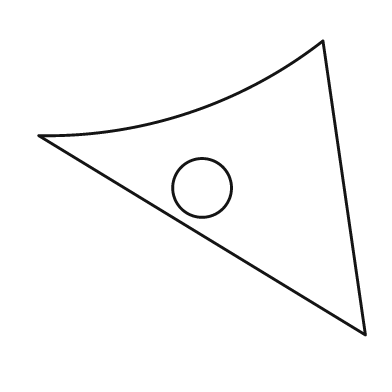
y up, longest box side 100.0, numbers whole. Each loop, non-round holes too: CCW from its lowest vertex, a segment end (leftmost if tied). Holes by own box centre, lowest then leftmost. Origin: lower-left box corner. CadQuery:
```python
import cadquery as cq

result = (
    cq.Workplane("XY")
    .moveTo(100.0, 0.0)
    .lineTo(87.0, 90.0)
    .threePointArc((46.0, 68.0), (0.0, 61.0))
    .close()
    .moveTo(50.0, 45.0)
    .circle(9.0)
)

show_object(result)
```